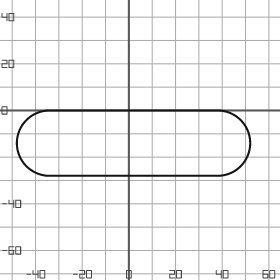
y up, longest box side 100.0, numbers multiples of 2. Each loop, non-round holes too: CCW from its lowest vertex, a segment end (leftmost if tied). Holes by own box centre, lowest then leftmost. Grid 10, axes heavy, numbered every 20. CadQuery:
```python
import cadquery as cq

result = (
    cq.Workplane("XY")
    .moveTo(-34.0, -28.0)
    .lineTo(38.0, -28.0)
    .threePointArc((52.0, -14.0), (38.0, 0.0))
    .lineTo(-34.0, 0.0)
    .threePointArc((-48.0, -14.0), (-34.0, -28.0))
    .close()
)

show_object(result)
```